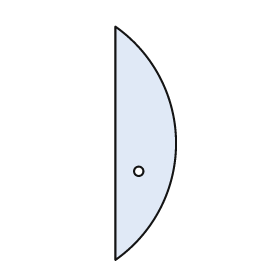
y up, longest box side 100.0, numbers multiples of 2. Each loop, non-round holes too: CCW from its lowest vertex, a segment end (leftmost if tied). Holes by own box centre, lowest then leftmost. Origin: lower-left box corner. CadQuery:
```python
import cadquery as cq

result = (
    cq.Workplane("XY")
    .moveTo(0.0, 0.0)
    .threePointArc((26.0, 50.0), (0.0, 100.0))
    .close()
    .moveTo(10.0, 38.0)
    .circle(2.0)
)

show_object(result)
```